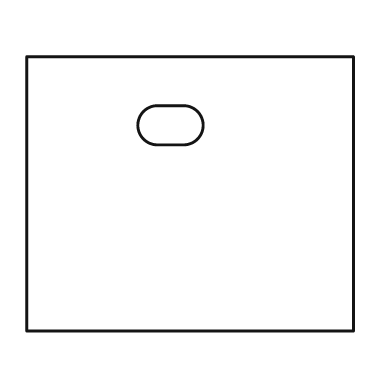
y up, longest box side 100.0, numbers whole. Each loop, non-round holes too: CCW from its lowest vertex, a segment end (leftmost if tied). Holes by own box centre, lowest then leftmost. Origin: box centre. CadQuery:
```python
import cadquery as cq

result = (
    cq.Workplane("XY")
    .moveTo(-50.0, -42.0)
    .lineTo(50.0, -42.0)
    .lineTo(50.0, 42.0)
    .lineTo(-50.0, 42.0)
    .close()
    .moveTo(-10.0, 15.0)
    .lineTo(-2.0, 15.0)
    .threePointArc((4.0, 21.0), (-2.0, 27.0))
    .lineTo(-10.0, 27.0)
    .threePointArc((-16.0, 21.0), (-10.0, 15.0))
    .close()
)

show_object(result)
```